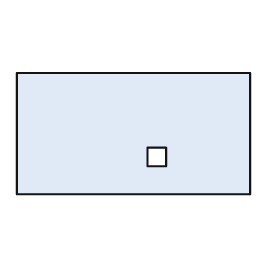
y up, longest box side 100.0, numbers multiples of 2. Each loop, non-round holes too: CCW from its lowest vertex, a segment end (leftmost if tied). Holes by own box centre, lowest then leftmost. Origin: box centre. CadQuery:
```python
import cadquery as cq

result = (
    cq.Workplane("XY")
    .moveTo(-50.0, -26.0)
    .lineTo(50.0, -26.0)
    .lineTo(50.0, 26.0)
    .lineTo(-50.0, 26.0)
    .close()
    .moveTo(6.0, -14.0)
    .lineTo(14.0, -14.0)
    .lineTo(14.0, -6.0)
    .lineTo(6.0, -6.0)
    .close()
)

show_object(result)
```